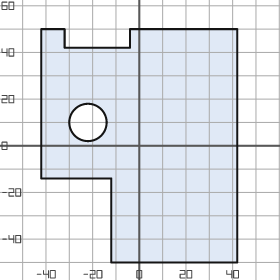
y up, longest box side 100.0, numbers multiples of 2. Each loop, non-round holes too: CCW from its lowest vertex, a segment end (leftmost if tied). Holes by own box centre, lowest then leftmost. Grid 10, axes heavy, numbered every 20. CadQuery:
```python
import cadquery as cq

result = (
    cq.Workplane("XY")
    .moveTo(-12.0, -50.0)
    .lineTo(42.0, -50.0)
    .lineTo(42.0, 50.0)
    .lineTo(-4.0, 50.0)
    .lineTo(-4.0, 42.0)
    .lineTo(-32.0, 42.0)
    .lineTo(-32.0, 50.0)
    .lineTo(-42.0, 50.0)
    .lineTo(-42.0, -14.0)
    .lineTo(-12.0, -14.0)
    .close()
    .moveTo(-22.0, 10.0)
    .circle(8.0)
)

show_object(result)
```